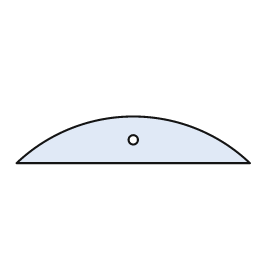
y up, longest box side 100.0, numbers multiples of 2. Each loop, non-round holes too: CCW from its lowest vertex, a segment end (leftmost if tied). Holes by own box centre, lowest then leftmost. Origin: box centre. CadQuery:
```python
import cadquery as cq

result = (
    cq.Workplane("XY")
    .moveTo(-50.0, -10.0)
    .lineTo(50.0, -10.0)
    .threePointArc((0.0, 10.0), (-50.0, -10.0))
    .close()
    .moveTo(0.0, 0.0)
    .circle(2.0)
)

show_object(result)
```